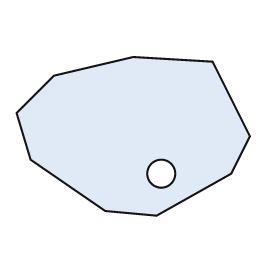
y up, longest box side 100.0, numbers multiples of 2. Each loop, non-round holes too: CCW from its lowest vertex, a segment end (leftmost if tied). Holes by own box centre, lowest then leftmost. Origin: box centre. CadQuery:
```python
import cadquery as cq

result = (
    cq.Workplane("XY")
    .moveTo(10.0, -34.0)
    .lineTo(42.0, -16.0)
    .lineTo(50.0, 0.0)
    .lineTo(34.0, 32.0)
    .lineTo(0.0, 34.0)
    .lineTo(-34.0, 26.0)
    .lineTo(-50.0, 10.0)
    .lineTo(-44.0, -10.0)
    .lineTo(-12.0, -32.0)
    .close()
    .moveTo(12.0, -16.0)
    .circle(6.0)
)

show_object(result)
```